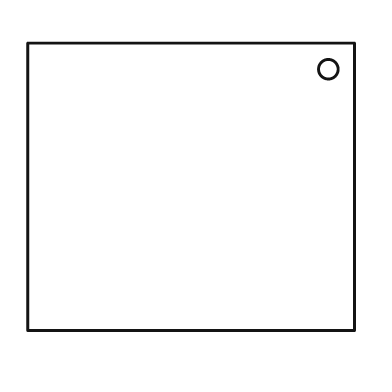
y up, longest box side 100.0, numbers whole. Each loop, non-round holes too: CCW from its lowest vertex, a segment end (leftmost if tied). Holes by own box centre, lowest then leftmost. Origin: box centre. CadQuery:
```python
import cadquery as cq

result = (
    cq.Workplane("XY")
    .moveTo(-50.0, -44.0)
    .lineTo(50.0, -44.0)
    .lineTo(50.0, 44.0)
    .lineTo(-50.0, 44.0)
    .close()
    .moveTo(42.0, 36.0)
    .circle(3.0)
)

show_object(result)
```